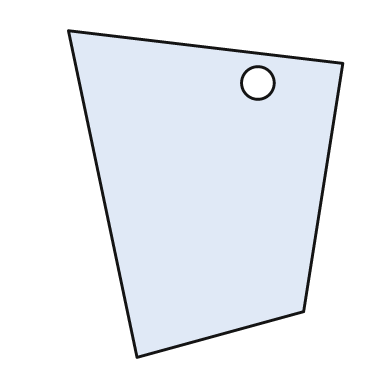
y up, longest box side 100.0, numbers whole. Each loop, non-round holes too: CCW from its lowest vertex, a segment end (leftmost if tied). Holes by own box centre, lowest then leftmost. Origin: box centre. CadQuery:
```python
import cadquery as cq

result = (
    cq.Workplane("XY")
    .moveTo(-21.0, -50.0)
    .lineTo(30.0, -36.0)
    .lineTo(42.0, 40.0)
    .lineTo(-42.0, 50.0)
    .close()
    .moveTo(16.0, 34.0)
    .circle(5.0)
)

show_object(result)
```